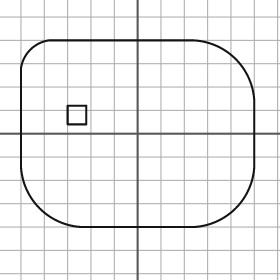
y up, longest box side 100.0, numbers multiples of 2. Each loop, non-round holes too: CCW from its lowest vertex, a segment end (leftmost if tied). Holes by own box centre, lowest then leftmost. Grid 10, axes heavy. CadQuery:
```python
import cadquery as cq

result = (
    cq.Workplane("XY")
    .moveTo(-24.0, -40.0)
    .lineTo(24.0, -40.0)
    .threePointArc((42.0, -32.0), (50.0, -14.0))
    .lineTo(50.0, 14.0)
    .threePointArc((42.0, 32.0), (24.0, 40.0))
    .lineTo(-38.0, 40.0)
    .threePointArc((-46.0, 36.0), (-50.0, 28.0))
    .lineTo(-50.0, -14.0)
    .threePointArc((-42.0, -32.0), (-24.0, -40.0))
    .close()
    .moveTo(-30.0, 4.0)
    .lineTo(-22.0, 4.0)
    .lineTo(-22.0, 12.0)
    .lineTo(-30.0, 12.0)
    .close()
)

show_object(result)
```